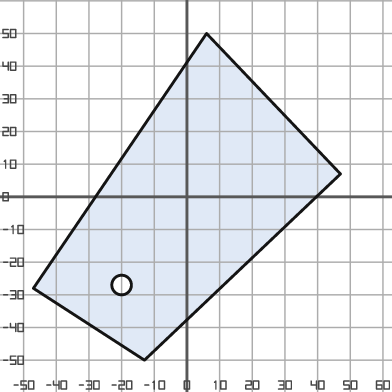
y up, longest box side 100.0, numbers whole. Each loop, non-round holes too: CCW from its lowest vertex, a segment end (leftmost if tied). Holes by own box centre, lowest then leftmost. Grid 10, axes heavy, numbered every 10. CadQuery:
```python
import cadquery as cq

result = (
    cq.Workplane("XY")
    .moveTo(-13.0, -50.0)
    .lineTo(47.0, 7.0)
    .lineTo(6.0, 50.0)
    .lineTo(-47.0, -28.0)
    .close()
    .moveTo(-20.0, -27.0)
    .circle(3.0)
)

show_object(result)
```